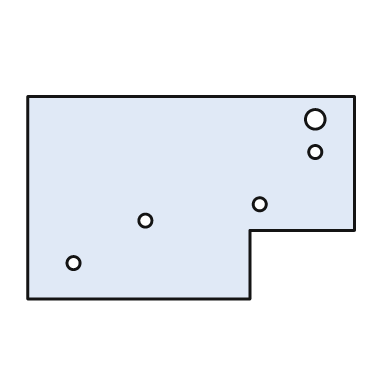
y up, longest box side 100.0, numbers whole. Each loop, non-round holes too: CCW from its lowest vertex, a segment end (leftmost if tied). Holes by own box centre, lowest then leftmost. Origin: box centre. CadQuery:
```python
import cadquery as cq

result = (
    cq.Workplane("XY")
    .moveTo(-50.0, -31.0)
    .lineTo(18.0, -31.0)
    .lineTo(18.0, -10.0)
    .lineTo(50.0, -10.0)
    .lineTo(50.0, 31.0)
    .lineTo(-50.0, 31.0)
    .close()
    .moveTo(-36.0, -20.0)
    .circle(2.0)
    .moveTo(-14.0, -7.0)
    .circle(2.0)
    .moveTo(21.0, -2.0)
    .circle(2.0)
    .moveTo(38.0, 14.0)
    .circle(2.0)
    .moveTo(38.0, 24.0)
    .circle(3.0)
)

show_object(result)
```